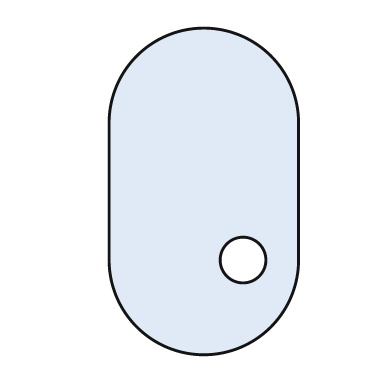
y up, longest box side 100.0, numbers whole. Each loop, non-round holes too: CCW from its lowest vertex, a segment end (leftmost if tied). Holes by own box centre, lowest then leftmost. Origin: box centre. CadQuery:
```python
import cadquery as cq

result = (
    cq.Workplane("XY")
    .moveTo(-29.0, -21.0)
    .threePointArc((0.0, -50.0), (29.0, -21.0))
    .lineTo(29.0, 21.0)
    .threePointArc((0.0, 50.0), (-29.0, 21.0))
    .close()
    .moveTo(12.0, -21.0)
    .circle(7.0)
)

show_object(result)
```